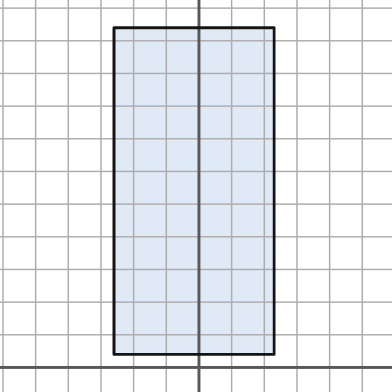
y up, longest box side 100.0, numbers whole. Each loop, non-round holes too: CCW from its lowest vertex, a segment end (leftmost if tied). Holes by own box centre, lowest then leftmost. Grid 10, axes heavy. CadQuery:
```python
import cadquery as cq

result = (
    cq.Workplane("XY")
    .moveTo(-26.0, 4.0)
    .lineTo(23.0, 4.0)
    .lineTo(23.0, 104.0)
    .lineTo(-26.0, 104.0)
    .close()
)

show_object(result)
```